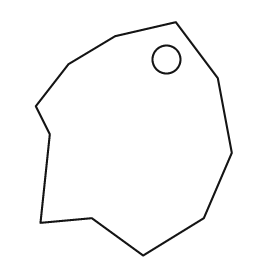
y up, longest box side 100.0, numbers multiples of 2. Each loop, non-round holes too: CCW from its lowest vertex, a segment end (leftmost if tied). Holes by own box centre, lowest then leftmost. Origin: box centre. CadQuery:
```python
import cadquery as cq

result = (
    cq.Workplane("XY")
    .moveTo(4.0, -50.0)
    .lineTo(30.0, -34.0)
    .lineTo(42.0, -6.0)
    .lineTo(36.0, 26.0)
    .lineTo(18.0, 50.0)
    .lineTo(-8.0, 44.0)
    .lineTo(-28.0, 32.0)
    .lineTo(-42.0, 14.0)
    .lineTo(-36.0, 2.0)
    .lineTo(-40.0, -36.0)
    .lineTo(-18.0, -34.0)
    .close()
    .moveTo(14.0, 34.0)
    .circle(6.0)
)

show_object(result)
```